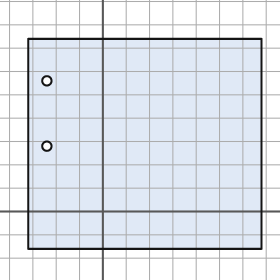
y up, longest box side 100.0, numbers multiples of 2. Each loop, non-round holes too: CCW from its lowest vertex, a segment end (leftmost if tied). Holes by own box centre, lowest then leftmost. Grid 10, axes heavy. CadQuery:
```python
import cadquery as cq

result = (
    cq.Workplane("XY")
    .moveTo(-32.0, -16.0)
    .lineTo(68.0, -16.0)
    .lineTo(68.0, 74.0)
    .lineTo(-32.0, 74.0)
    .close()
    .moveTo(-24.0, 28.0)
    .circle(2.0)
    .moveTo(-24.0, 56.0)
    .circle(2.0)
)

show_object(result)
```